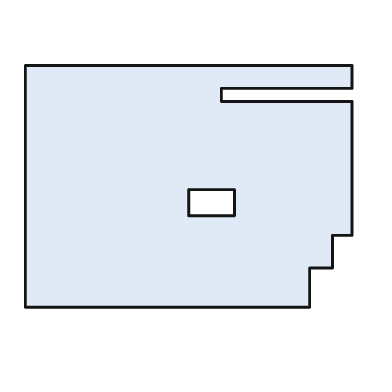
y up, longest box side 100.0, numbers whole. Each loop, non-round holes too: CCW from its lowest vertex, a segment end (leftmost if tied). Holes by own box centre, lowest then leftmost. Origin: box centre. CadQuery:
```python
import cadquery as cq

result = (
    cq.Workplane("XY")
    .moveTo(-50.0, -37.0)
    .lineTo(37.0, -37.0)
    .lineTo(37.0, -25.0)
    .lineTo(44.0, -25.0)
    .lineTo(44.0, -15.0)
    .lineTo(50.0, -15.0)
    .lineTo(50.0, 26.0)
    .lineTo(10.0, 26.0)
    .lineTo(10.0, 30.0)
    .lineTo(50.0, 30.0)
    .lineTo(50.0, 37.0)
    .lineTo(-50.0, 37.0)
    .close()
    .moveTo(0.0, -9.0)
    .lineTo(14.0, -9.0)
    .lineTo(14.0, -1.0)
    .lineTo(0.0, -1.0)
    .close()
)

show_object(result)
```